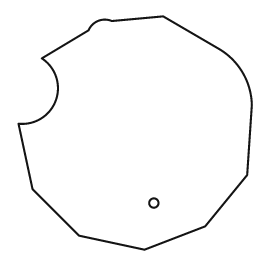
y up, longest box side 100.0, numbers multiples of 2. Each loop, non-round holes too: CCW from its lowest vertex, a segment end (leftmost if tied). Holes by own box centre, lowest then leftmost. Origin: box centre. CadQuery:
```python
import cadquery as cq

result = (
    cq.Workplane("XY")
    .moveTo(4.0, -50.0)
    .lineTo(30.0, -40.0)
    .lineTo(48.0, -18.0)
    .lineTo(50.0, 12.0)
    .threePointArc((46.0, 26.0), (36.0, 36.0))
    .lineTo(12.0, 50.0)
    .lineTo(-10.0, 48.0)
    .threePointArc((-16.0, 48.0), (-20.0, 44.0))
    .lineTo(-40.0, 32.0)
    .threePointArc((-34.0, 14.0), (-50.0, 4.0))
    .lineTo(-44.0, -24.0)
    .lineTo(-24.0, -44.0)
    .close()
    .moveTo(8.0, -30.0)
    .circle(2.0)
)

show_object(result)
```